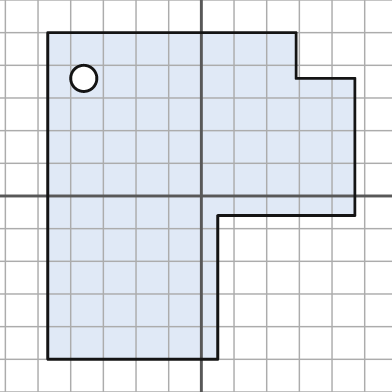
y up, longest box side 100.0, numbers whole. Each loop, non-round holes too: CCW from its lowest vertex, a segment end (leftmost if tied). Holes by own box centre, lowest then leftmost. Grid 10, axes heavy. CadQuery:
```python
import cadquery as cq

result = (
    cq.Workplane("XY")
    .moveTo(-47.0, -50.0)
    .lineTo(5.0, -50.0)
    .lineTo(5.0, -6.0)
    .lineTo(47.0, -6.0)
    .lineTo(47.0, 36.0)
    .lineTo(29.0, 36.0)
    .lineTo(29.0, 50.0)
    .lineTo(-47.0, 50.0)
    .close()
    .moveTo(-36.0, 36.0)
    .circle(4.0)
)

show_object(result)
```